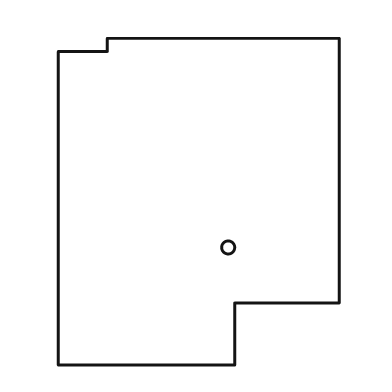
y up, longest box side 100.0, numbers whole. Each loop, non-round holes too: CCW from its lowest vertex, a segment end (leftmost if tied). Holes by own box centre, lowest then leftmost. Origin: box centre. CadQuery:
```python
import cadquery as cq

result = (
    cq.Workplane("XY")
    .moveTo(-43.0, -50.0)
    .lineTo(11.0, -50.0)
    .lineTo(11.0, -31.0)
    .lineTo(43.0, -31.0)
    .lineTo(43.0, 50.0)
    .lineTo(-28.0, 50.0)
    .lineTo(-28.0, 46.0)
    .lineTo(-43.0, 46.0)
    .close()
    .moveTo(9.0, -14.0)
    .circle(2.0)
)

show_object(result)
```